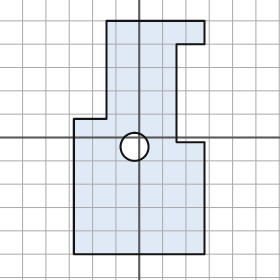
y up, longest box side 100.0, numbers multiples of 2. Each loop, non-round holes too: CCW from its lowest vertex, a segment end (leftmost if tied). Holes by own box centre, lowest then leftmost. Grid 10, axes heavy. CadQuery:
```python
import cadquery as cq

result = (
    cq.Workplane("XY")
    .moveTo(-28.0, -50.0)
    .lineTo(28.0, -50.0)
    .lineTo(28.0, -2.0)
    .lineTo(16.0, -2.0)
    .lineTo(16.0, 40.0)
    .lineTo(28.0, 40.0)
    .lineTo(28.0, 50.0)
    .lineTo(-14.0, 50.0)
    .lineTo(-14.0, 8.0)
    .lineTo(-28.0, 8.0)
    .close()
    .moveTo(-2.0, -4.0)
    .circle(6.0)
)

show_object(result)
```